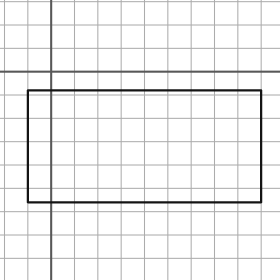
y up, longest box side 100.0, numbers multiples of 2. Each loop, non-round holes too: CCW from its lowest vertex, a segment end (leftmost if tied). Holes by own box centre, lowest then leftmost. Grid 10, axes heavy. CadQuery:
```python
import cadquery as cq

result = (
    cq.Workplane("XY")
    .moveTo(-10.0, -56.0)
    .lineTo(90.0, -56.0)
    .lineTo(90.0, -8.0)
    .lineTo(-10.0, -8.0)
    .close()
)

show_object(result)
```